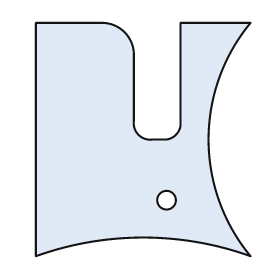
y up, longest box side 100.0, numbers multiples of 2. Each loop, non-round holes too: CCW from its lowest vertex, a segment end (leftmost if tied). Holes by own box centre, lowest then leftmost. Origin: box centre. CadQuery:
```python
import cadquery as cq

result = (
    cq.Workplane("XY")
    .moveTo(-46.0, -50.0)
    .threePointArc((0.0, -42.0), (46.0, -50.0))
    .threePointArc((28.0, 0.0), (46.0, 50.0))
    .lineTo(16.0, 50.0)
    .lineTo(16.0, 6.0)
    .threePointArc((14.0, 2.0), (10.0, 0.0))
    .lineTo(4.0, 0.0)
    .threePointArc((-2.0, 2.0), (-4.0, 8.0))
    .lineTo(-4.0, 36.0)
    .threePointArc((-8.0, 46.0), (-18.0, 50.0))
    .lineTo(-46.0, 50.0)
    .close()
    .moveTo(10.0, -26.0)
    .circle(4.0)
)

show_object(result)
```